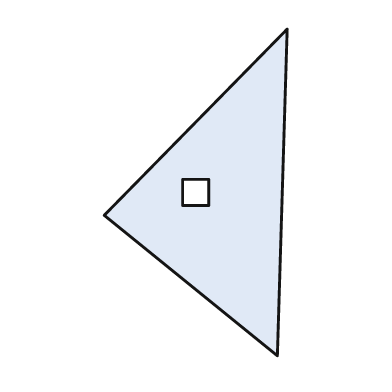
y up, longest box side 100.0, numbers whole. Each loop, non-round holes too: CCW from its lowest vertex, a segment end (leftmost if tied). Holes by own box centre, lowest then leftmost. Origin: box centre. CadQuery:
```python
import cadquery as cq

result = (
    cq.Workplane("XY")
    .moveTo(25.0, -50.0)
    .lineTo(28.0, 50.0)
    .lineTo(-28.0, -7.0)
    .close()
    .moveTo(-4.0, -4.0)
    .lineTo(4.0, -4.0)
    .lineTo(4.0, 4.0)
    .lineTo(-4.0, 4.0)
    .close()
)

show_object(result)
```